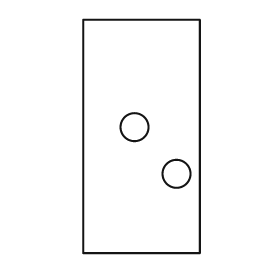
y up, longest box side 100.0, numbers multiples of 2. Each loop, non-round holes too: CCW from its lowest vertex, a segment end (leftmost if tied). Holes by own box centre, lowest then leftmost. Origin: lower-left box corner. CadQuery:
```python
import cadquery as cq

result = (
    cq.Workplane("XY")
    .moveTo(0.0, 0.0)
    .lineTo(50.0, 0.0)
    .lineTo(50.0, 100.0)
    .lineTo(0.0, 100.0)
    .close()
    .moveTo(40.0, 34.0)
    .circle(6.0)
    .moveTo(22.0, 54.0)
    .circle(6.0)
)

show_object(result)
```